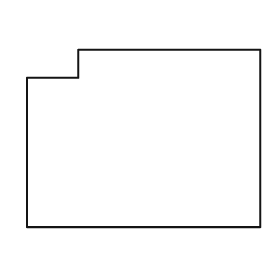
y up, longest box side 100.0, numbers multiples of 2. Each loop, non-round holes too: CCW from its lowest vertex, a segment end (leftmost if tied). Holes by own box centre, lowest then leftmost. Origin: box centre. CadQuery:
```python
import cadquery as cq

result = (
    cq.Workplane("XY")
    .moveTo(-50.0, -38.0)
    .lineTo(50.0, -38.0)
    .lineTo(50.0, 38.0)
    .lineTo(-28.0, 38.0)
    .lineTo(-28.0, 26.0)
    .lineTo(-50.0, 26.0)
    .close()
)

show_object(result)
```